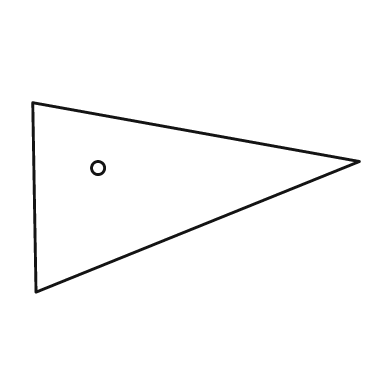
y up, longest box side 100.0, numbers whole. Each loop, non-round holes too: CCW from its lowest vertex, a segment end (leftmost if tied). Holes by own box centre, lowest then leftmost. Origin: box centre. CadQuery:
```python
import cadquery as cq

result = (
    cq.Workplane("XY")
    .moveTo(-49.0, -29.0)
    .lineTo(50.0, 11.0)
    .lineTo(-50.0, 29.0)
    .close()
    .moveTo(-30.0, 9.0)
    .circle(2.0)
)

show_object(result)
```